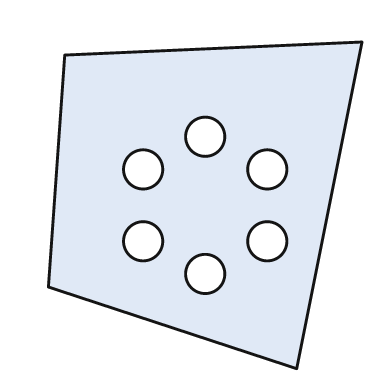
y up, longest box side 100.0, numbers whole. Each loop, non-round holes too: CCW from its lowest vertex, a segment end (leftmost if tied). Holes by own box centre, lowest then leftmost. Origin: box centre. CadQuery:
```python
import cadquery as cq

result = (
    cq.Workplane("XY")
    .moveTo(28.0, -50.0)
    .lineTo(48.0, 50.0)
    .lineTo(-43.0, 46.0)
    .lineTo(-48.0, -25.0)
    .close()
    .moveTo(0.0, -21.0)
    .circle(6.0)
    .moveTo(-19.0, -11.0)
    .circle(6.0)
    .moveTo(19.0, -11.0)
    .circle(6.0)
    .moveTo(-19.0, 11.0)
    .circle(6.0)
    .moveTo(19.0, 11.0)
    .circle(6.0)
    .moveTo(0.0, 21.0)
    .circle(6.0)
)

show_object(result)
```